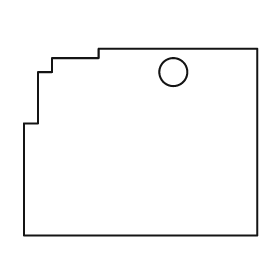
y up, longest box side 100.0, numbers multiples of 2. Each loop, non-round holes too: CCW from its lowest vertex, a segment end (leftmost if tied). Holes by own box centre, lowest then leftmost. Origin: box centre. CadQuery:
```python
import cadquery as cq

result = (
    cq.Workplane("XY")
    .moveTo(-50.0, -40.0)
    .lineTo(50.0, -40.0)
    .lineTo(50.0, 40.0)
    .lineTo(-18.0, 40.0)
    .lineTo(-18.0, 36.0)
    .lineTo(-38.0, 36.0)
    .lineTo(-38.0, 30.0)
    .lineTo(-44.0, 30.0)
    .lineTo(-44.0, 8.0)
    .lineTo(-50.0, 8.0)
    .close()
    .moveTo(14.0, 30.0)
    .circle(6.0)
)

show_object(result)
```